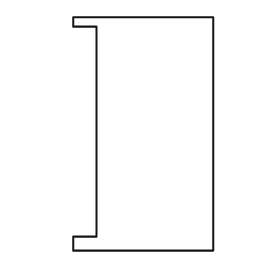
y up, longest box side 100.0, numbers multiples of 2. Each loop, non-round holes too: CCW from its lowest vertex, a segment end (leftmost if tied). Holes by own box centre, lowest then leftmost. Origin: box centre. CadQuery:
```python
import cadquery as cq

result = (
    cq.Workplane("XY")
    .moveTo(-30.0, -50.0)
    .lineTo(30.0, -50.0)
    .lineTo(30.0, 50.0)
    .lineTo(-30.0, 50.0)
    .lineTo(-30.0, 46.0)
    .lineTo(-20.0, 46.0)
    .lineTo(-20.0, -44.0)
    .lineTo(-30.0, -44.0)
    .close()
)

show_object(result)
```